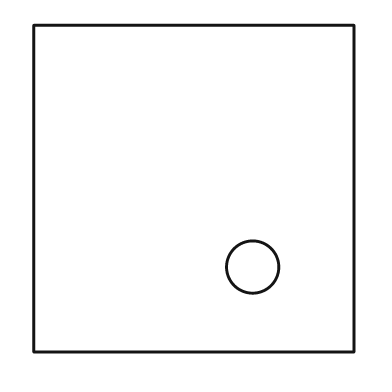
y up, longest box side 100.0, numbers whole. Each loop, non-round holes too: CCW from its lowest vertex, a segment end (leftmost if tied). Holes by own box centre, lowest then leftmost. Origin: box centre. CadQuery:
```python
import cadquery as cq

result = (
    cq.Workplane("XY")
    .moveTo(-49.0, -50.0)
    .lineTo(49.0, -50.0)
    .lineTo(49.0, 50.0)
    .lineTo(-49.0, 50.0)
    .close()
    .moveTo(18.0, -24.0)
    .circle(8.0)
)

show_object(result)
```